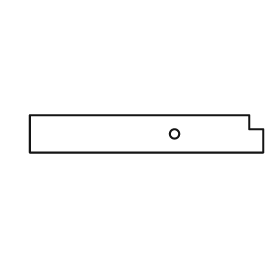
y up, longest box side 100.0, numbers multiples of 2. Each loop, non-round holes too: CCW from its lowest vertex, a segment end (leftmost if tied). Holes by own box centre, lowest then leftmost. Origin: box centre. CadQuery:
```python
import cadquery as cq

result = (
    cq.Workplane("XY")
    .moveTo(-50.0, -8.0)
    .lineTo(50.0, -8.0)
    .lineTo(50.0, 2.0)
    .lineTo(44.0, 2.0)
    .lineTo(44.0, 8.0)
    .lineTo(-50.0, 8.0)
    .close()
    .moveTo(12.0, 0.0)
    .circle(2.0)
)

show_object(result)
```